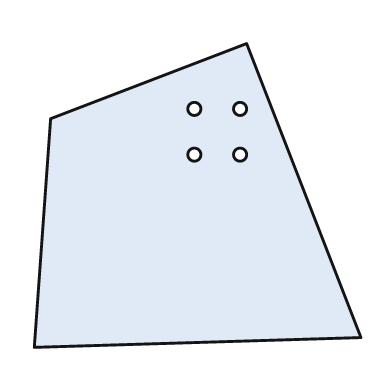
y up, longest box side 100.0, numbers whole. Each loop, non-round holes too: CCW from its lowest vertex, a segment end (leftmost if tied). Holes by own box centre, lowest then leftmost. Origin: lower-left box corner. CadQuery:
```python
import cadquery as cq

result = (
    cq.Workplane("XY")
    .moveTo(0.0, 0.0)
    .lineTo(100.0, 3.0)
    .lineTo(65.0, 93.0)
    .lineTo(5.0, 70.0)
    .close()
    .moveTo(49.0, 59.0)
    .circle(2.0)
    .moveTo(63.0, 59.0)
    .circle(2.0)
    .moveTo(49.0, 73.0)
    .circle(2.0)
    .moveTo(63.0, 73.0)
    .circle(2.0)
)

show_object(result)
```